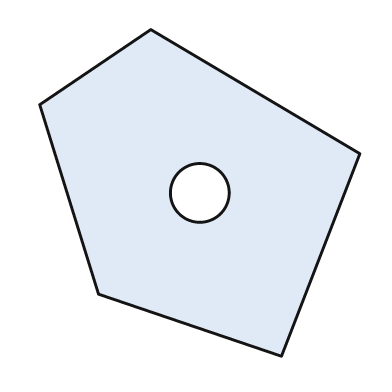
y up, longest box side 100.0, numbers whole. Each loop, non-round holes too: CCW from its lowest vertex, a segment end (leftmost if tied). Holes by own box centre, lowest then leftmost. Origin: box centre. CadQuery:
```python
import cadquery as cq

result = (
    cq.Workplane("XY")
    .moveTo(25.0, -50.0)
    .lineTo(49.0, 12.0)
    .lineTo(-15.0, 50.0)
    .lineTo(-49.0, 27.0)
    .lineTo(-31.0, -31.0)
    .close()
    .moveTo(0.0, 0.0)
    .circle(9.0)
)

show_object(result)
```